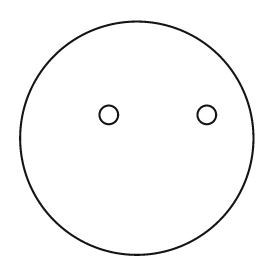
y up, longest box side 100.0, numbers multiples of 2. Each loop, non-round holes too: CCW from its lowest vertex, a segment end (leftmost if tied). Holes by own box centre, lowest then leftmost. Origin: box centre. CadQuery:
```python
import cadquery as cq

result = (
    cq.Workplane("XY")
    .moveTo(0.0, 0.0)
    .circle(50.0)
    .moveTo(-12.0, 10.0)
    .circle(4.0)
    .moveTo(30.0, 10.0)
    .circle(4.0)
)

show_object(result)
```